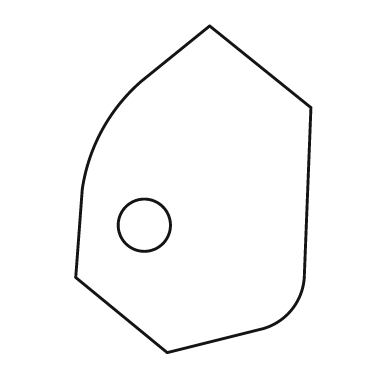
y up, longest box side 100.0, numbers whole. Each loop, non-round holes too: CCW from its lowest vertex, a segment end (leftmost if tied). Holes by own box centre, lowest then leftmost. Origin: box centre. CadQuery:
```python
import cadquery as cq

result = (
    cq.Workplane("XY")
    .moveTo(-8.0, -50.0)
    .lineTo(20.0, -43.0)
    .threePointArc((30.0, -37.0), (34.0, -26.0))
    .lineTo(36.0, 25.0)
    .lineTo(5.0, 50.0)
    .lineTo(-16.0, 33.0)
    .threePointArc((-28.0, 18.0), (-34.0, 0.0))
    .lineTo(-36.0, -27.0)
    .close()
    .moveTo(-15.0, -11.0)
    .circle(8.0)
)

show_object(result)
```